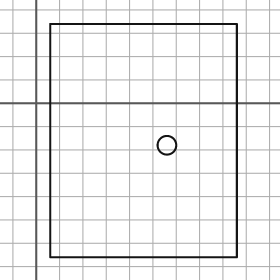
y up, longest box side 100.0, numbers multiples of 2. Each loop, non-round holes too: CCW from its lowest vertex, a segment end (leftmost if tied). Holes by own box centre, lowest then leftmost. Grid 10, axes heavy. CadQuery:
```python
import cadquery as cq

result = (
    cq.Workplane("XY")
    .moveTo(6.0, -66.0)
    .lineTo(86.0, -66.0)
    .lineTo(86.0, 34.0)
    .lineTo(6.0, 34.0)
    .close()
    .moveTo(56.0, -18.0)
    .circle(4.0)
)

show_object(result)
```